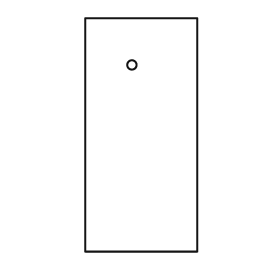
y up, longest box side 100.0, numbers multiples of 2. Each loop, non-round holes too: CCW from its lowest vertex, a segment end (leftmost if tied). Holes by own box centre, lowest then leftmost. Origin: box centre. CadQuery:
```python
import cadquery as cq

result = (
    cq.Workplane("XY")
    .moveTo(-24.0, -50.0)
    .lineTo(24.0, -50.0)
    .lineTo(24.0, 50.0)
    .lineTo(-24.0, 50.0)
    .close()
    .moveTo(-4.0, 30.0)
    .circle(2.0)
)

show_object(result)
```